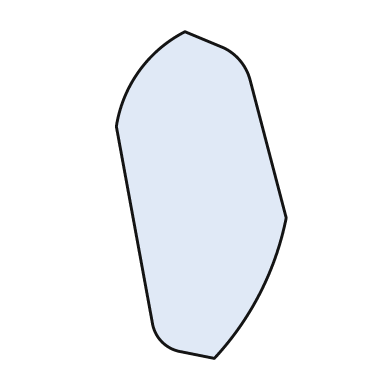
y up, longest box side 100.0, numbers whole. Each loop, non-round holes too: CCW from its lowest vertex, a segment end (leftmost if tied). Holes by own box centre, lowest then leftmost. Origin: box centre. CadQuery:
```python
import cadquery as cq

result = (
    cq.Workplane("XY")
    .moveTo(4.0, -50.0)
    .threePointArc((18.0, -30.0), (26.0, -7.0))
    .lineTo(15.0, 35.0)
    .threePointArc((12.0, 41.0), (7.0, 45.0))
    .lineTo(-5.0, 50.0)
    .threePointArc((-19.0, 38.0), (-26.0, 21.0))
    .lineTo(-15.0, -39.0)
    .threePointArc((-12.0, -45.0), (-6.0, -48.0))
    .close()
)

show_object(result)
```